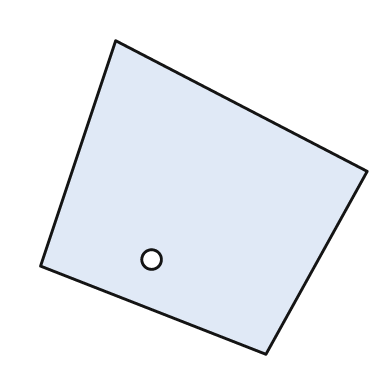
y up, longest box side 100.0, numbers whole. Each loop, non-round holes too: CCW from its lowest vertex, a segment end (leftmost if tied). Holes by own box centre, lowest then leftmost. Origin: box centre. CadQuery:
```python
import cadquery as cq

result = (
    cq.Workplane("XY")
    .moveTo(19.0, -48.0)
    .lineTo(50.0, 8.0)
    .lineTo(-27.0, 48.0)
    .lineTo(-50.0, -21.0)
    .close()
    .moveTo(-16.0, -19.0)
    .circle(3.0)
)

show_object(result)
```